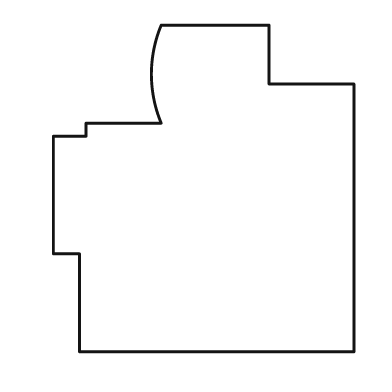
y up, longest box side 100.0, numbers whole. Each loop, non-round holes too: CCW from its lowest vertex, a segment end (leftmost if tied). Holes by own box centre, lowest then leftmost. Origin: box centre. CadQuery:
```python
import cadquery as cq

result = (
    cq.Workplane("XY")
    .moveTo(-38.0, -50.0)
    .lineTo(46.0, -50.0)
    .lineTo(46.0, 32.0)
    .lineTo(20.0, 32.0)
    .lineTo(20.0, 50.0)
    .lineTo(-13.0, 50.0)
    .threePointArc((-16.0, 35.0), (-13.0, 20.0))
    .lineTo(-36.0, 20.0)
    .lineTo(-36.0, 16.0)
    .lineTo(-46.0, 16.0)
    .lineTo(-46.0, -20.0)
    .lineTo(-38.0, -20.0)
    .close()
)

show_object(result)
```